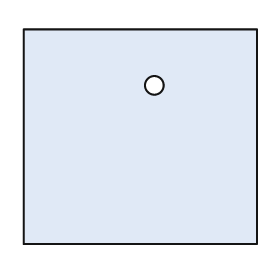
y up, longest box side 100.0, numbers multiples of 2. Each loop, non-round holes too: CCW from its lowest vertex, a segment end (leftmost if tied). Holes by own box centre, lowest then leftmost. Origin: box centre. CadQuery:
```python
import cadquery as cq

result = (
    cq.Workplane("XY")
    .moveTo(-50.0, -46.0)
    .lineTo(50.0, -46.0)
    .lineTo(50.0, 46.0)
    .lineTo(-50.0, 46.0)
    .close()
    .moveTo(6.0, 22.0)
    .circle(4.0)
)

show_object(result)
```